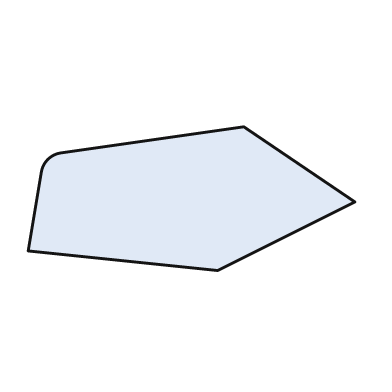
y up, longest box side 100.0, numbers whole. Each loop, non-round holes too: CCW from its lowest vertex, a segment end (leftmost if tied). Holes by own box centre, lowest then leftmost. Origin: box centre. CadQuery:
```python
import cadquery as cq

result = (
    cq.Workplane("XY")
    .moveTo(8.0, -22.0)
    .lineTo(50.0, -1.0)
    .lineTo(16.0, 22.0)
    .lineTo(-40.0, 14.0)
    .threePointArc((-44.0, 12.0), (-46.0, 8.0))
    .lineTo(-50.0, -16.0)
    .close()
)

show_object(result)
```